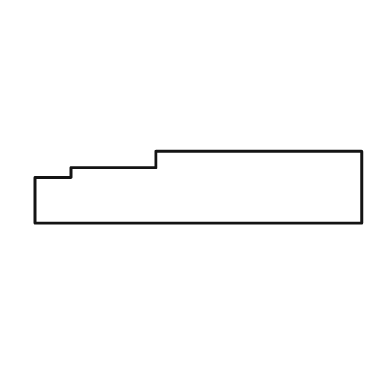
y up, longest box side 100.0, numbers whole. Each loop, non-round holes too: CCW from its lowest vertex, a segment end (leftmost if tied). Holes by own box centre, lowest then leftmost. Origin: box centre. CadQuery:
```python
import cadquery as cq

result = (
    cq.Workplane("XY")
    .moveTo(-50.0, -11.0)
    .lineTo(50.0, -11.0)
    .lineTo(50.0, 11.0)
    .lineTo(-13.0, 11.0)
    .lineTo(-13.0, 6.0)
    .lineTo(-39.0, 6.0)
    .lineTo(-39.0, 3.0)
    .lineTo(-50.0, 3.0)
    .close()
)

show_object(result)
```